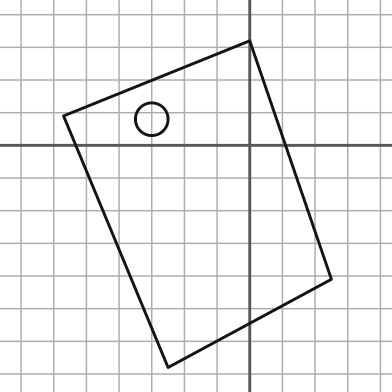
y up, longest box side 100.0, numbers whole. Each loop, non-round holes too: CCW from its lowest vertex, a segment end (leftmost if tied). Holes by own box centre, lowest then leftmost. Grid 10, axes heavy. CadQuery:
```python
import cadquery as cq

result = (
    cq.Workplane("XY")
    .moveTo(-25.0, -68.0)
    .lineTo(25.0, -41.0)
    .lineTo(0.0, 32.0)
    .lineTo(-57.0, 9.0)
    .close()
    .moveTo(-30.0, 8.0)
    .circle(5.0)
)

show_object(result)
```